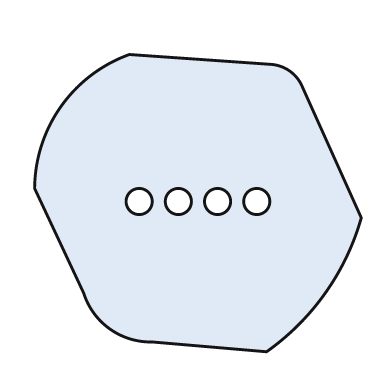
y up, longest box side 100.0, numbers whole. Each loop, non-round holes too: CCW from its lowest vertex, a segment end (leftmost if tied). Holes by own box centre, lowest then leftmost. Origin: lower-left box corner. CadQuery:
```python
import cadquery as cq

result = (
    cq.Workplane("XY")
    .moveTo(71.0, 0.0)
    .threePointArc((89.0, 18.0), (100.0, 41.0))
    .lineTo(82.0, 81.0)
    .threePointArc((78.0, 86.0), (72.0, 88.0))
    .lineTo(29.0, 91.0)
    .threePointArc((8.0, 75.0), (0.0, 50.0))
    .lineTo(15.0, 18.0)
    .threePointArc((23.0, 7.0), (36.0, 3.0))
    .close()
    .moveTo(32.0, 46.0)
    .circle(4.0)
    .moveTo(44.0, 46.0)
    .circle(4.0)
    .moveTo(56.0, 46.0)
    .circle(4.0)
    .moveTo(68.0, 46.0)
    .circle(4.0)
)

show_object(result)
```